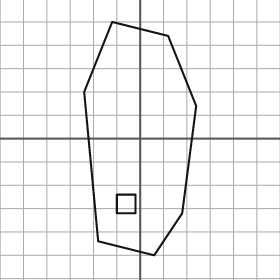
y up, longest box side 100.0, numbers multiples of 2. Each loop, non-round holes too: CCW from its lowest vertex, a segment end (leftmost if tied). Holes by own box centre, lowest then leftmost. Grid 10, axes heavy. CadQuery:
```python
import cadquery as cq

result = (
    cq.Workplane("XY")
    .moveTo(6.0, -50.0)
    .lineTo(18.0, -32.0)
    .lineTo(24.0, 14.0)
    .lineTo(12.0, 44.0)
    .lineTo(-12.0, 50.0)
    .lineTo(-24.0, 20.0)
    .lineTo(-18.0, -44.0)
    .close()
    .moveTo(-10.0, -32.0)
    .lineTo(-2.0, -32.0)
    .lineTo(-2.0, -24.0)
    .lineTo(-10.0, -24.0)
    .close()
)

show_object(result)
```